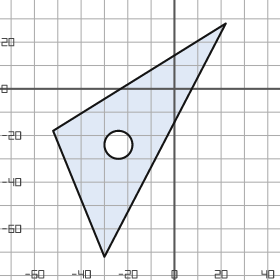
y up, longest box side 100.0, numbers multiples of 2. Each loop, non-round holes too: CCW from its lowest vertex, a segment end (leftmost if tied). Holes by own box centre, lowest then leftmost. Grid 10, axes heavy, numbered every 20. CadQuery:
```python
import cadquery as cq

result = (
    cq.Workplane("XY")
    .moveTo(-30.0, -72.0)
    .lineTo(22.0, 28.0)
    .lineTo(-52.0, -18.0)
    .close()
    .moveTo(-24.0, -24.0)
    .circle(6.0)
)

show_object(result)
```